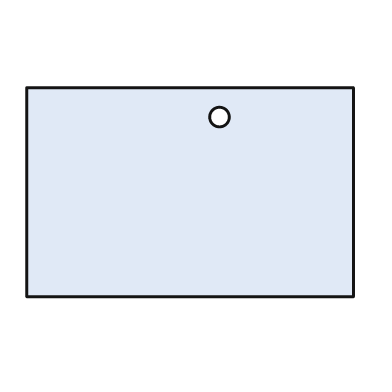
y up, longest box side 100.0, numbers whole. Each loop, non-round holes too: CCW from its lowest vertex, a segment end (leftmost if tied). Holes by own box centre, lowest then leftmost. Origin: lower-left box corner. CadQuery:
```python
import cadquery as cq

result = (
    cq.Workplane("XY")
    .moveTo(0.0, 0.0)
    .lineTo(100.0, 0.0)
    .lineTo(100.0, 64.0)
    .lineTo(0.0, 64.0)
    .close()
    .moveTo(59.0, 55.0)
    .circle(3.0)
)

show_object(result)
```